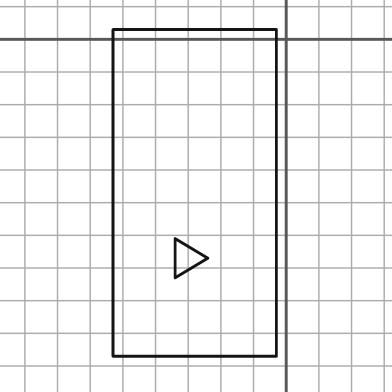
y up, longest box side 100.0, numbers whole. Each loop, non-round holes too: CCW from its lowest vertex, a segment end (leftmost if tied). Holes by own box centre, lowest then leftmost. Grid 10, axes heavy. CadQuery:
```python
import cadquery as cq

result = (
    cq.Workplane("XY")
    .moveTo(-53.0, -97.0)
    .lineTo(-3.0, -97.0)
    .lineTo(-3.0, 3.0)
    .lineTo(-53.0, 3.0)
    .close()
    .moveTo(-34.0, -73.0)
    .lineTo(-24.0, -67.0)
    .lineTo(-34.0, -61.0)
    .close()
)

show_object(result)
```